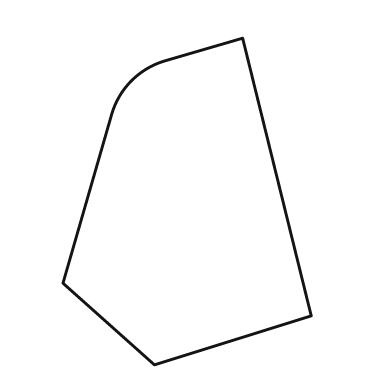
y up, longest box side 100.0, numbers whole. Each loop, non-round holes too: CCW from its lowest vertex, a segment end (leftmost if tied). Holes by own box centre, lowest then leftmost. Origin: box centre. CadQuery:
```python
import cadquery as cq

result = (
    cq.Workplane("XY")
    .moveTo(-10.0, -50.0)
    .lineTo(38.0, -35.0)
    .lineTo(17.0, 50.0)
    .lineTo(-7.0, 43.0)
    .threePointArc((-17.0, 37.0), (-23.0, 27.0))
    .lineTo(-38.0, -25.0)
    .close()
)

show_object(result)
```